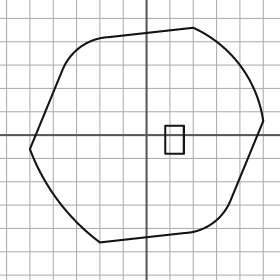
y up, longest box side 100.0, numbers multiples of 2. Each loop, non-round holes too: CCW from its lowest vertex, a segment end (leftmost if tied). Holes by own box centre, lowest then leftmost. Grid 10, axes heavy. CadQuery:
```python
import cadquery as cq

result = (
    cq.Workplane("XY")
    .moveTo(-20.0, -46.0)
    .lineTo(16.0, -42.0)
    .threePointArc((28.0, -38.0), (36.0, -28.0))
    .lineTo(50.0, 6.0)
    .threePointArc((40.0, 30.0), (20.0, 46.0))
    .lineTo(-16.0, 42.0)
    .threePointArc((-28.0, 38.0), (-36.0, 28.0))
    .lineTo(-50.0, -6.0)
    .threePointArc((-38.0, -28.0), (-20.0, -46.0))
    .close()
    .moveTo(8.0, -8.0)
    .lineTo(16.0, -8.0)
    .lineTo(16.0, 4.0)
    .lineTo(8.0, 4.0)
    .close()
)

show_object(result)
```